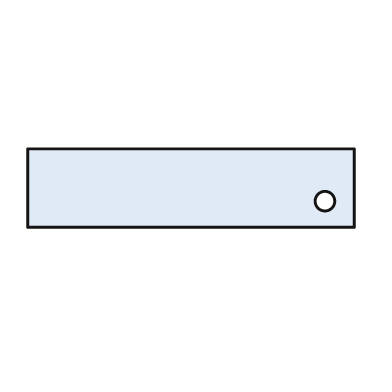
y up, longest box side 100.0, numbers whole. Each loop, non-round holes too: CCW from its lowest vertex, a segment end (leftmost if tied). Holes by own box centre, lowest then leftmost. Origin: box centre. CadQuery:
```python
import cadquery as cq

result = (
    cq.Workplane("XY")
    .moveTo(-50.0, -12.0)
    .lineTo(50.0, -12.0)
    .lineTo(50.0, 12.0)
    .lineTo(-50.0, 12.0)
    .close()
    .moveTo(41.0, -4.0)
    .circle(3.0)
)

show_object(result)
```